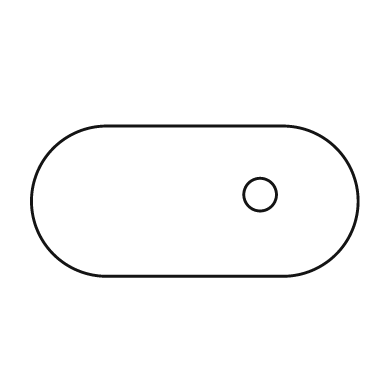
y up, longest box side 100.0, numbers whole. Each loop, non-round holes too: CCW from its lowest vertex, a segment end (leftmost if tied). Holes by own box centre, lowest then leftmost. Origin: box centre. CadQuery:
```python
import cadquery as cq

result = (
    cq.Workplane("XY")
    .moveTo(-27.0, -23.0)
    .lineTo(27.0, -23.0)
    .threePointArc((50.0, 0.0), (27.0, 23.0))
    .lineTo(-27.0, 23.0)
    .threePointArc((-50.0, 0.0), (-27.0, -23.0))
    .close()
    .moveTo(20.0, 2.0)
    .circle(5.0)
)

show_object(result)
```